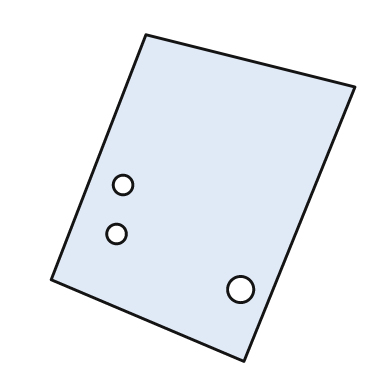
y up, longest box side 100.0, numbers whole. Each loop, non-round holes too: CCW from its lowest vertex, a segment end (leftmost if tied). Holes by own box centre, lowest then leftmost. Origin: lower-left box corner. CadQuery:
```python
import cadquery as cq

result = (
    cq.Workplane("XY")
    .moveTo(59.0, 0.0)
    .lineTo(93.0, 84.0)
    .lineTo(29.0, 100.0)
    .lineTo(0.0, 25.0)
    .close()
    .moveTo(58.0, 22.0)
    .circle(4.0)
    .moveTo(20.0, 39.0)
    .circle(3.0)
    .moveTo(22.0, 54.0)
    .circle(3.0)
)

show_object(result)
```